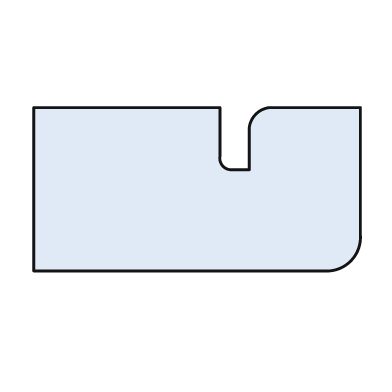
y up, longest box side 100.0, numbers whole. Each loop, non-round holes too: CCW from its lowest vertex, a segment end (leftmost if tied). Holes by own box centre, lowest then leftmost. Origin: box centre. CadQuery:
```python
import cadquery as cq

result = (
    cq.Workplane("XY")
    .moveTo(-50.0, -25.0)
    .lineTo(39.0, -25.0)
    .threePointArc((47.0, -22.0), (50.0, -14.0))
    .lineTo(50.0, 25.0)
    .lineTo(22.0, 25.0)
    .threePointArc((18.0, 23.0), (16.0, 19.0))
    .lineTo(16.0, 6.0)
    .lineTo(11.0, 6.0)
    .threePointArc((8.0, 7.0), (7.0, 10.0))
    .lineTo(7.0, 25.0)
    .lineTo(-50.0, 25.0)
    .close()
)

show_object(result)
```